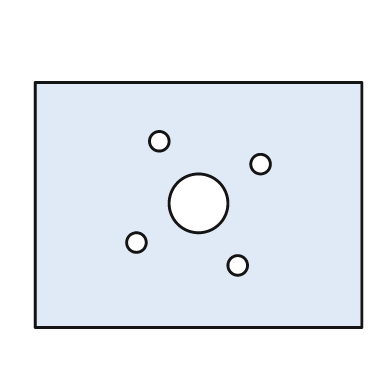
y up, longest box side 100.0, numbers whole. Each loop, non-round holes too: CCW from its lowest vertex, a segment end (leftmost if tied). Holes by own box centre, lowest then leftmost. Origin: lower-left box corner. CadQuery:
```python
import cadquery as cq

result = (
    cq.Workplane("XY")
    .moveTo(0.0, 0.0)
    .lineTo(100.0, 0.0)
    .lineTo(100.0, 75.0)
    .lineTo(0.0, 75.0)
    .close()
    .moveTo(62.0, 19.0)
    .circle(3.0)
    .moveTo(31.0, 26.0)
    .circle(3.0)
    .moveTo(50.0, 38.0)
    .circle(9.0)
    .moveTo(69.0, 50.0)
    .circle(3.0)
    .moveTo(38.0, 57.0)
    .circle(3.0)
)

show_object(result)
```